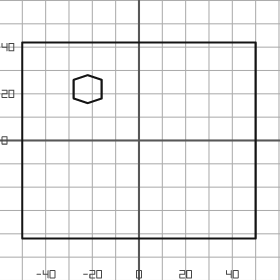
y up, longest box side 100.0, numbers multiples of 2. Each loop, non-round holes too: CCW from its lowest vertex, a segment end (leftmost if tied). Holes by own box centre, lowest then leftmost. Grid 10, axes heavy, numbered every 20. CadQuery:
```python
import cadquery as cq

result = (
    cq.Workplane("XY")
    .moveTo(-50.0, -42.0)
    .lineTo(50.0, -42.0)
    .lineTo(50.0, 42.0)
    .lineTo(-50.0, 42.0)
    .close()
    .moveTo(-22.0, 16.0)
    .lineTo(-16.0, 18.0)
    .lineTo(-16.0, 26.0)
    .lineTo(-22.0, 28.0)
    .lineTo(-28.0, 26.0)
    .lineTo(-28.0, 18.0)
    .close()
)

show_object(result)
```